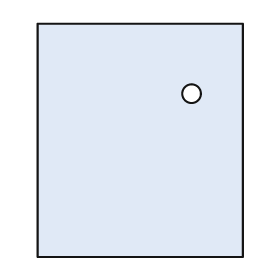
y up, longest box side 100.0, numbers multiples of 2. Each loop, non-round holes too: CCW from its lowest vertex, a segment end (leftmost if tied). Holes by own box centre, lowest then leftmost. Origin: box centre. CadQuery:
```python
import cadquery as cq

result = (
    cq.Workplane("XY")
    .moveTo(-44.0, -50.0)
    .lineTo(44.0, -50.0)
    .lineTo(44.0, 50.0)
    .lineTo(-44.0, 50.0)
    .close()
    .moveTo(22.0, 20.0)
    .circle(4.0)
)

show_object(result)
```